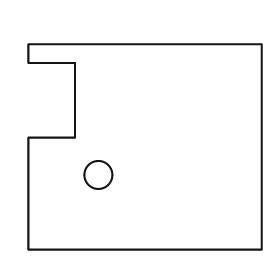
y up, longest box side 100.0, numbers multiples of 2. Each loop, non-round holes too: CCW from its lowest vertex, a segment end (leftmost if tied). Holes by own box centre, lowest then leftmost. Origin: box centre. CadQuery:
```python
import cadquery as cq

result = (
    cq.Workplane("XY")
    .moveTo(-50.0, -44.0)
    .lineTo(50.0, -44.0)
    .lineTo(50.0, 44.0)
    .lineTo(-50.0, 44.0)
    .lineTo(-50.0, 36.0)
    .lineTo(-30.0, 36.0)
    .lineTo(-30.0, 4.0)
    .lineTo(-50.0, 4.0)
    .close()
    .moveTo(-20.0, -12.0)
    .circle(6.0)
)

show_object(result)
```